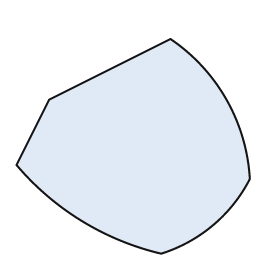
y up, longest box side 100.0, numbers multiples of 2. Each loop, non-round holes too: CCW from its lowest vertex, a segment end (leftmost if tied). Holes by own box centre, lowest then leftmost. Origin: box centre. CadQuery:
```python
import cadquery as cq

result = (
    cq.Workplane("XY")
    .moveTo(12.0, -46.0)
    .threePointArc((34.0, -34.0), (50.0, -14.0))
    .threePointArc((40.0, 20.0), (16.0, 46.0))
    .lineTo(-36.0, 20.0)
    .lineTo(-50.0, -8.0)
    .threePointArc((-22.0, -32.0), (12.0, -46.0))
    .close()
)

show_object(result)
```